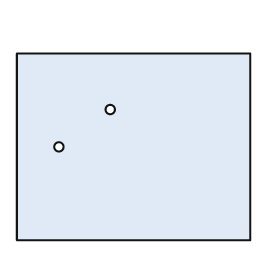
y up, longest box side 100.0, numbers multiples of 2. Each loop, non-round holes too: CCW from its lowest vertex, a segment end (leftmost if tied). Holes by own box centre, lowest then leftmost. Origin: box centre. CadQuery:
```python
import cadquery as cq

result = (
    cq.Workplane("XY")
    .moveTo(-50.0, -40.0)
    .lineTo(50.0, -40.0)
    .lineTo(50.0, 40.0)
    .lineTo(-50.0, 40.0)
    .close()
    .moveTo(-32.0, 0.0)
    .circle(2.0)
    .moveTo(-10.0, 16.0)
    .circle(2.0)
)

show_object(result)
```